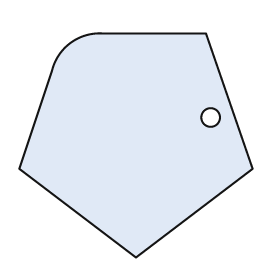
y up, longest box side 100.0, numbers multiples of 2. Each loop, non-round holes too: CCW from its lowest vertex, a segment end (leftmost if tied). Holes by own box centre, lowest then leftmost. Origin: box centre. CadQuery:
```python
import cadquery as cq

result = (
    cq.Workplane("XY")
    .moveTo(0.0, -48.0)
    .lineTo(50.0, -10.0)
    .lineTo(30.0, 48.0)
    .lineTo(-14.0, 48.0)
    .threePointArc((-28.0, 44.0), (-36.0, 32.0))
    .lineTo(-50.0, -10.0)
    .close()
    .moveTo(32.0, 12.0)
    .circle(4.0)
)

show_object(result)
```